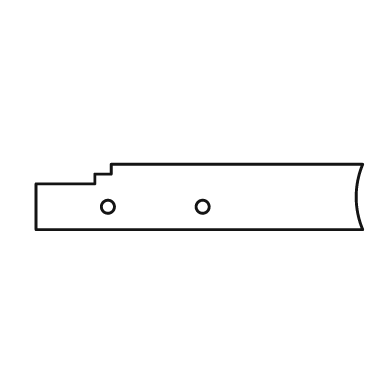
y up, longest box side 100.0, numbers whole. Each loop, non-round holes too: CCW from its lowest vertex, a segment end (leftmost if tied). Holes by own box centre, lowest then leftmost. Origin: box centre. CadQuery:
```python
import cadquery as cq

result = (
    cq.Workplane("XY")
    .moveTo(-50.0, -10.0)
    .lineTo(50.0, -10.0)
    .threePointArc((48.0, 0.0), (50.0, 10.0))
    .lineTo(-27.0, 10.0)
    .lineTo(-27.0, 7.0)
    .lineTo(-32.0, 7.0)
    .lineTo(-32.0, 4.0)
    .lineTo(-50.0, 4.0)
    .close()
    .moveTo(-28.0, -3.0)
    .circle(2.0)
    .moveTo(1.0, -3.0)
    .circle(2.0)
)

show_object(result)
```